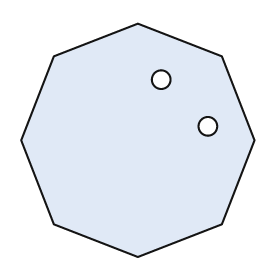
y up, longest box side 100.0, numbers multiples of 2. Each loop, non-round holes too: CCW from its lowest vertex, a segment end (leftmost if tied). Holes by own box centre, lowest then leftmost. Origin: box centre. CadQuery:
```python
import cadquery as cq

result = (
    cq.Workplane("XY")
    .moveTo(0.0, -50.0)
    .lineTo(36.0, -36.0)
    .lineTo(50.0, 0.0)
    .lineTo(36.0, 36.0)
    .lineTo(0.0, 50.0)
    .lineTo(-36.0, 36.0)
    .lineTo(-50.0, 0.0)
    .lineTo(-36.0, -36.0)
    .close()
    .moveTo(30.0, 6.0)
    .circle(4.0)
    .moveTo(10.0, 26.0)
    .circle(4.0)
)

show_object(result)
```